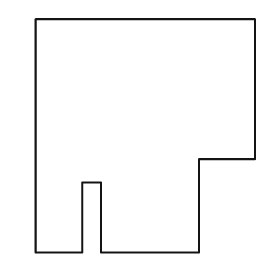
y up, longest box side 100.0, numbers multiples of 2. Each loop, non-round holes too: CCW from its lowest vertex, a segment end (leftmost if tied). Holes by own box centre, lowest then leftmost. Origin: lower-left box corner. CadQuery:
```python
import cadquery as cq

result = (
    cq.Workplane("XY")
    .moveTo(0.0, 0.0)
    .lineTo(20.0, 0.0)
    .lineTo(20.0, 30.0)
    .lineTo(28.0, 30.0)
    .lineTo(28.0, 0.0)
    .lineTo(70.0, 0.0)
    .lineTo(70.0, 40.0)
    .lineTo(94.0, 40.0)
    .lineTo(94.0, 100.0)
    .lineTo(0.0, 100.0)
    .close()
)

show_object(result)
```